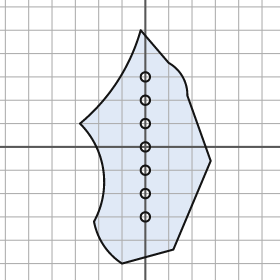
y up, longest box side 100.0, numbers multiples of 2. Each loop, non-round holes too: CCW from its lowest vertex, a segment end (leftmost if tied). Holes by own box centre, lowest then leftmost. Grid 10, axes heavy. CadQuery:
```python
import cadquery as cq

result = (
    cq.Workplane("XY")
    .moveTo(-10.0, -50.0)
    .lineTo(12.0, -44.0)
    .lineTo(28.0, -6.0)
    .lineTo(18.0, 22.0)
    .threePointArc((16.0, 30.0), (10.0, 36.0))
    .lineTo(-2.0, 50.0)
    .threePointArc((-12.0, 28.0), (-28.0, 10.0))
    .threePointArc((-18.0, -10.0), (-22.0, -32.0))
    .threePointArc((-18.0, -42.0), (-10.0, -50.0))
    .close()
    .moveTo(0.0, -30.0)
    .circle(2.0)
    .moveTo(0.0, -20.0)
    .circle(2.0)
    .moveTo(0.0, -10.0)
    .circle(2.0)
    .moveTo(0.0, 0.0)
    .circle(2.0)
    .moveTo(0.0, 10.0)
    .circle(2.0)
    .moveTo(0.0, 20.0)
    .circle(2.0)
    .moveTo(0.0, 30.0)
    .circle(2.0)
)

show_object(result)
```